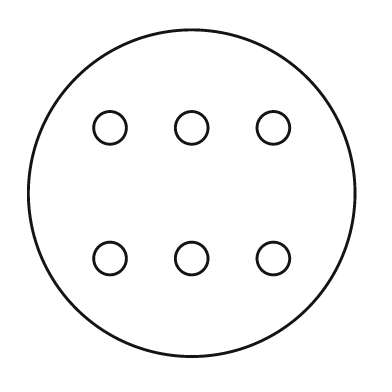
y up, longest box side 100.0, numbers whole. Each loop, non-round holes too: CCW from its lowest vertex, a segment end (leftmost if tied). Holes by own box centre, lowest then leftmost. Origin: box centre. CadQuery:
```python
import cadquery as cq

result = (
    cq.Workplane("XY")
    .moveTo(0.0, 0.0)
    .circle(50.0)
    .moveTo(-25.0, -20.0)
    .circle(5.0)
    .moveTo(0.0, -20.0)
    .circle(5.0)
    .moveTo(25.0, -20.0)
    .circle(5.0)
    .moveTo(-25.0, 20.0)
    .circle(5.0)
    .moveTo(0.0, 20.0)
    .circle(5.0)
    .moveTo(25.0, 20.0)
    .circle(5.0)
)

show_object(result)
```